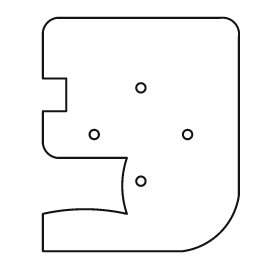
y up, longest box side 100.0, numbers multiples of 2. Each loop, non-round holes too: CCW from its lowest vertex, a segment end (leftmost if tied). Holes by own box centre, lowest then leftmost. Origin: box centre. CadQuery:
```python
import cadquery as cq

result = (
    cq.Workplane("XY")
    .moveTo(-42.0, -50.0)
    .lineTo(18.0, -50.0)
    .threePointArc((34.0, -42.0), (42.0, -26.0))
    .lineTo(42.0, 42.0)
    .threePointArc((40.0, 48.0), (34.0, 50.0))
    .lineTo(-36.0, 50.0)
    .threePointArc((-40.0, 48.0), (-42.0, 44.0))
    .lineTo(-42.0, 24.0)
    .lineTo(-32.0, 24.0)
    .lineTo(-32.0, 10.0)
    .lineTo(-42.0, 10.0)
    .lineTo(-42.0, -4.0)
    .threePointArc((-40.0, -8.0), (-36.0, -10.0))
    .lineTo(-6.0, -10.0)
    .threePointArc((-8.0, -22.0), (-6.0, -34.0))
    .threePointArc((-24.0, -32.0), (-42.0, -34.0))
    .close()
    .moveTo(0.0, -20.0)
    .circle(2.0)
    .moveTo(-20.0, 0.0)
    .circle(2.0)
    .moveTo(20.0, 0.0)
    .circle(2.0)
    .moveTo(0.0, 20.0)
    .circle(2.0)
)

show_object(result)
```